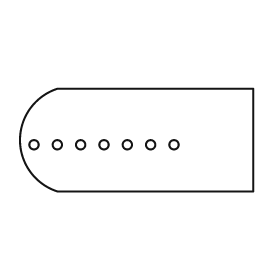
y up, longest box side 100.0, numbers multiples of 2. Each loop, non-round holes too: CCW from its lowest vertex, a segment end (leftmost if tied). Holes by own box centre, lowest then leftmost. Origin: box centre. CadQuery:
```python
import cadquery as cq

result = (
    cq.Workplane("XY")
    .moveTo(-34.0, -22.0)
    .lineTo(50.0, -22.0)
    .lineTo(50.0, 22.0)
    .lineTo(-34.0, 22.0)
    .threePointArc((-50.0, 0.0), (-34.0, -22.0))
    .close()
    .moveTo(-44.0, -2.0)
    .circle(2.0)
    .moveTo(-34.0, -2.0)
    .circle(2.0)
    .moveTo(-24.0, -2.0)
    .circle(2.0)
    .moveTo(-14.0, -2.0)
    .circle(2.0)
    .moveTo(-4.0, -2.0)
    .circle(2.0)
    .moveTo(6.0, -2.0)
    .circle(2.0)
    .moveTo(16.0, -2.0)
    .circle(2.0)
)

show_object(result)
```